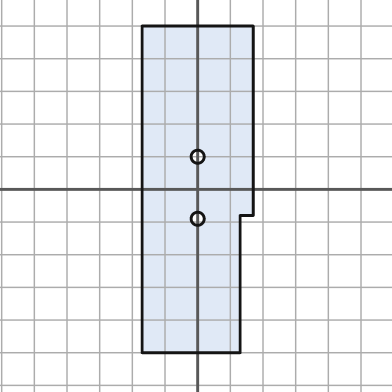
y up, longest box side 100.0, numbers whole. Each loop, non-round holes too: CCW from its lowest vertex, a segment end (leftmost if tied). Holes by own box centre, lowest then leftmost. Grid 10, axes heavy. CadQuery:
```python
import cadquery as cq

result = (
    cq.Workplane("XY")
    .moveTo(-17.0, -50.0)
    .lineTo(13.0, -50.0)
    .lineTo(13.0, -8.0)
    .lineTo(17.0, -8.0)
    .lineTo(17.0, 50.0)
    .lineTo(-17.0, 50.0)
    .close()
    .moveTo(0.0, -9.0)
    .circle(2.0)
    .moveTo(0.0, 10.0)
    .circle(2.0)
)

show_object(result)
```